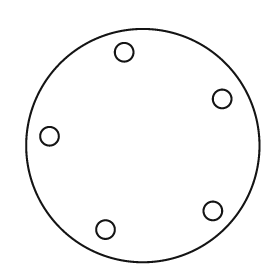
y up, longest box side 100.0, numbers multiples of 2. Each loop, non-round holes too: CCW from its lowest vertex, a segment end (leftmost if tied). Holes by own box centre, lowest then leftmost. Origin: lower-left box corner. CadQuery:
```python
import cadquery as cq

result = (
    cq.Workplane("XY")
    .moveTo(50.0, 50.0)
    .circle(50.0)
    .moveTo(34.0, 14.0)
    .circle(4.0)
    .moveTo(80.0, 22.0)
    .circle(4.0)
    .moveTo(10.0, 54.0)
    .circle(4.0)
    .moveTo(84.0, 70.0)
    .circle(4.0)
    .moveTo(42.0, 90.0)
    .circle(4.0)
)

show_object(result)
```